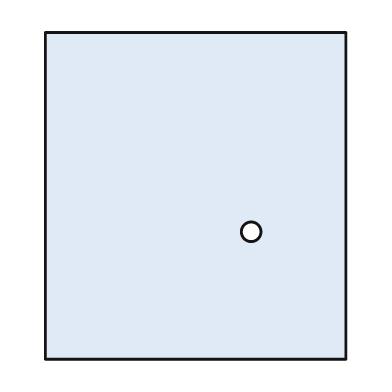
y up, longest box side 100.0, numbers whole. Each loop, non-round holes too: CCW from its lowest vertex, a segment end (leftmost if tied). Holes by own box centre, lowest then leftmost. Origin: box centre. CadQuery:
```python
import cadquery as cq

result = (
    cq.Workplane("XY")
    .moveTo(-46.0, -50.0)
    .lineTo(46.0, -50.0)
    .lineTo(46.0, 50.0)
    .lineTo(-46.0, 50.0)
    .close()
    .moveTo(17.0, -11.0)
    .circle(3.0)
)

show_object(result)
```